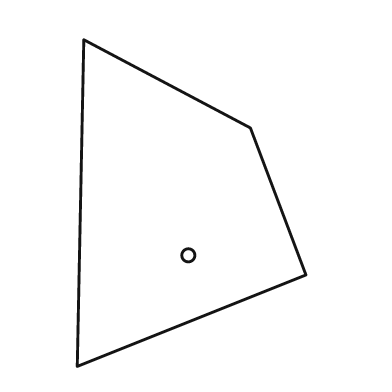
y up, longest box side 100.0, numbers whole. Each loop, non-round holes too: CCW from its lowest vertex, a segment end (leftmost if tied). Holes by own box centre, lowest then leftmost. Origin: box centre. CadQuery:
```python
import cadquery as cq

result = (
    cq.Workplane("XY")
    .moveTo(-35.0, -50.0)
    .lineTo(35.0, -22.0)
    .lineTo(18.0, 23.0)
    .lineTo(-33.0, 50.0)
    .close()
    .moveTo(-1.0, -16.0)
    .circle(2.0)
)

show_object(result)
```